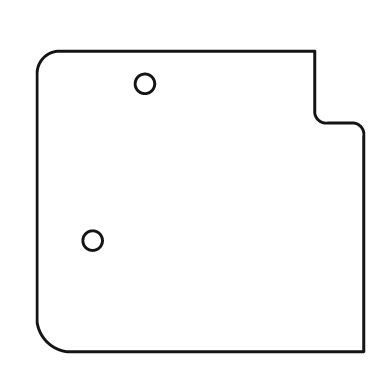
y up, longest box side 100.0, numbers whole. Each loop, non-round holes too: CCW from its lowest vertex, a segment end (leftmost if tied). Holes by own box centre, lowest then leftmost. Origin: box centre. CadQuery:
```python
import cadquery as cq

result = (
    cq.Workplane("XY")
    .moveTo(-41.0, -46.0)
    .lineTo(50.0, -46.0)
    .lineTo(50.0, 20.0)
    .threePointArc((49.0, 23.0), (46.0, 24.0))
    .lineTo(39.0, 24.0)
    .threePointArc((36.0, 25.0), (35.0, 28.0))
    .lineTo(35.0, 46.0)
    .lineTo(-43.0, 46.0)
    .threePointArc((-48.0, 44.0), (-50.0, 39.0))
    .lineTo(-50.0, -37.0)
    .threePointArc((-47.0, -43.0), (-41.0, -46.0))
    .close()
    .moveTo(-33.0, -12.0)
    .circle(3.0)
    .moveTo(-17.0, 36.0)
    .circle(3.0)
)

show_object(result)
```